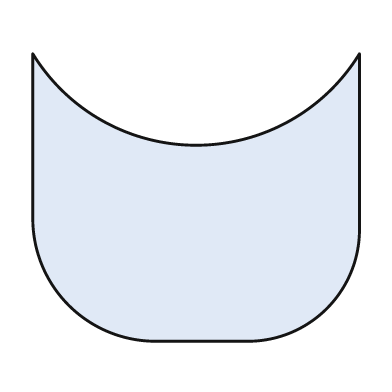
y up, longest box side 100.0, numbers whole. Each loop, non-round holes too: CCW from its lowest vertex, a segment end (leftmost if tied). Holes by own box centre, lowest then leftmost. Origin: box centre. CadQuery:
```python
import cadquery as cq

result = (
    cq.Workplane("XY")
    .moveTo(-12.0, -44.0)
    .lineTo(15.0, -44.0)
    .threePointArc((40.0, -34.0), (50.0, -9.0))
    .lineTo(50.0, 44.0)
    .threePointArc((0.0, 16.0), (-50.0, 44.0))
    .lineTo(-50.0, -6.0)
    .threePointArc((-39.0, -33.0), (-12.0, -44.0))
    .close()
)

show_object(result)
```